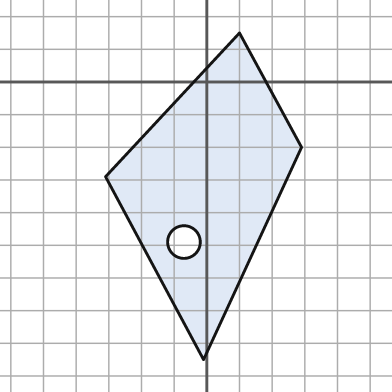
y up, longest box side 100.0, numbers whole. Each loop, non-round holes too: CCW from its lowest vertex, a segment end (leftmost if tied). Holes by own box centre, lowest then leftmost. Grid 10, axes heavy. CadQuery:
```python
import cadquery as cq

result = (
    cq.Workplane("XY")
    .moveTo(-1.0, -85.0)
    .lineTo(29.0, -20.0)
    .lineTo(10.0, 15.0)
    .lineTo(-31.0, -29.0)
    .close()
    .moveTo(-7.0, -49.0)
    .circle(5.0)
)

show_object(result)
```